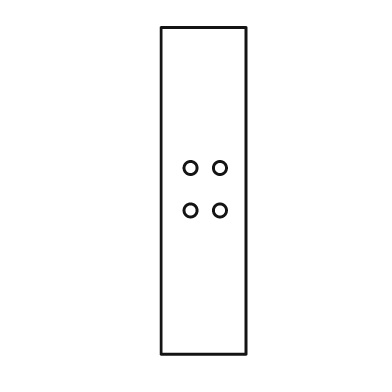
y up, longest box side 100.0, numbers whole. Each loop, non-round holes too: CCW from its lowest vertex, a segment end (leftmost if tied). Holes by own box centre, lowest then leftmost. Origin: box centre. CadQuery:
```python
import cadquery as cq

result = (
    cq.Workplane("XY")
    .moveTo(-13.0, -50.0)
    .lineTo(13.0, -50.0)
    .lineTo(13.0, 50.0)
    .lineTo(-13.0, 50.0)
    .close()
    .moveTo(-4.0, -6.0)
    .circle(2.0)
    .moveTo(5.0, -6.0)
    .circle(2.0)
    .moveTo(-4.0, 7.0)
    .circle(2.0)
    .moveTo(5.0, 7.0)
    .circle(2.0)
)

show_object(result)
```